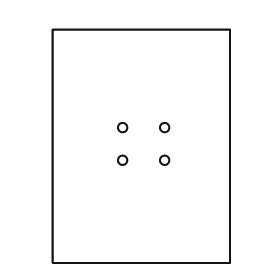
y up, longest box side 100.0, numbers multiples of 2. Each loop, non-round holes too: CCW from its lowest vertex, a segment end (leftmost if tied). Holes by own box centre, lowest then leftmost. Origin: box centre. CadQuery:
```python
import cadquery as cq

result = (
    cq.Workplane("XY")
    .moveTo(-38.0, -50.0)
    .lineTo(38.0, -50.0)
    .lineTo(38.0, 50.0)
    .lineTo(-38.0, 50.0)
    .close()
    .moveTo(-8.0, -6.0)
    .circle(2.0)
    .moveTo(10.0, -6.0)
    .circle(2.0)
    .moveTo(-8.0, 8.0)
    .circle(2.0)
    .moveTo(10.0, 8.0)
    .circle(2.0)
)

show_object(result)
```